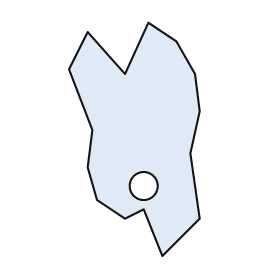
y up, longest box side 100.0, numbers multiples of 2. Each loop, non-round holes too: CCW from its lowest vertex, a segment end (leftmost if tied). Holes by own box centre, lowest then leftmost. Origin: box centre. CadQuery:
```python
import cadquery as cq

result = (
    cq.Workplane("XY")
    .moveTo(12.0, -50.0)
    .lineTo(28.0, -34.0)
    .lineTo(24.0, -6.0)
    .lineTo(28.0, 12.0)
    .lineTo(26.0, 28.0)
    .lineTo(18.0, 42.0)
    .lineTo(6.0, 50.0)
    .lineTo(-4.0, 28.0)
    .lineTo(-20.0, 46.0)
    .lineTo(-28.0, 30.0)
    .lineTo(-18.0, 4.0)
    .lineTo(-20.0, -12.0)
    .lineTo(-16.0, -26.0)
    .lineTo(-4.0, -34.0)
    .lineTo(4.0, -30.0)
    .close()
    .moveTo(4.0, -20.0)
    .circle(6.0)
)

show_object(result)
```